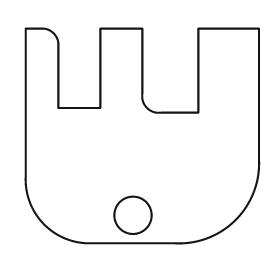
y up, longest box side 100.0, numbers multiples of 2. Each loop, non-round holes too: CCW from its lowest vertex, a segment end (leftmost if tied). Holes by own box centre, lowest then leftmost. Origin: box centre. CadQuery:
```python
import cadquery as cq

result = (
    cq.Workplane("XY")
    .moveTo(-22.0, -46.0)
    .lineTo(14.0, -46.0)
    .threePointArc((40.0, -36.0), (50.0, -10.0))
    .lineTo(50.0, 46.0)
    .lineTo(24.0, 46.0)
    .lineTo(24.0, 10.0)
    .lineTo(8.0, 10.0)
    .threePointArc((2.0, 12.0), (0.0, 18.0))
    .lineTo(0.0, 46.0)
    .lineTo(-18.0, 46.0)
    .lineTo(-18.0, 12.0)
    .lineTo(-36.0, 12.0)
    .lineTo(-36.0, 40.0)
    .threePointArc((-38.0, 44.0), (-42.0, 46.0))
    .lineTo(-50.0, 46.0)
    .lineTo(-50.0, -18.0)
    .threePointArc((-42.0, -38.0), (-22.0, -46.0))
    .close()
    .moveTo(-4.0, -34.0)
    .circle(8.0)
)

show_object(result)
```